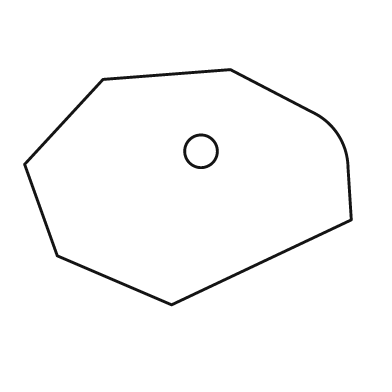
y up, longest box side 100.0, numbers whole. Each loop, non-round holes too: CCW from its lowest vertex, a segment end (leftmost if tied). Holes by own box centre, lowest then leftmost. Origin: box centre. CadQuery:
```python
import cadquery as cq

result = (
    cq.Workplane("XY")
    .moveTo(-5.0, -36.0)
    .lineTo(50.0, -10.0)
    .lineTo(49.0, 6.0)
    .threePointArc((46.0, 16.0), (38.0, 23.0))
    .lineTo(13.0, 36.0)
    .lineTo(-26.0, 33.0)
    .lineTo(-50.0, 7.0)
    .lineTo(-40.0, -21.0)
    .close()
    .moveTo(4.0, 11.0)
    .circle(5.0)
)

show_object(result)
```